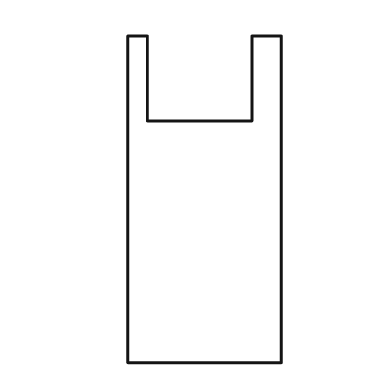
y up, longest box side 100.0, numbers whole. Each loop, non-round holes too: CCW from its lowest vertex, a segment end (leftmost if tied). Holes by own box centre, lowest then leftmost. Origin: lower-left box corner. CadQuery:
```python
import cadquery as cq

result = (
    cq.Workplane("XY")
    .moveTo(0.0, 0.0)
    .lineTo(47.0, 0.0)
    .lineTo(47.0, 100.0)
    .lineTo(38.0, 100.0)
    .lineTo(38.0, 74.0)
    .lineTo(6.0, 74.0)
    .lineTo(6.0, 100.0)
    .lineTo(0.0, 100.0)
    .close()
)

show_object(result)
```